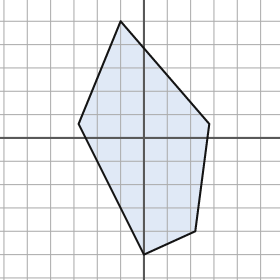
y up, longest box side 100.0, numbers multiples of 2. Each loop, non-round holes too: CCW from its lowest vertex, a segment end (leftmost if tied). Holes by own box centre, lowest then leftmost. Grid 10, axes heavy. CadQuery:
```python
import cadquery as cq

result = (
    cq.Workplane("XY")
    .moveTo(0.0, -50.0)
    .lineTo(22.0, -40.0)
    .lineTo(28.0, 6.0)
    .lineTo(-10.0, 50.0)
    .lineTo(-28.0, 6.0)
    .close()
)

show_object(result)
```